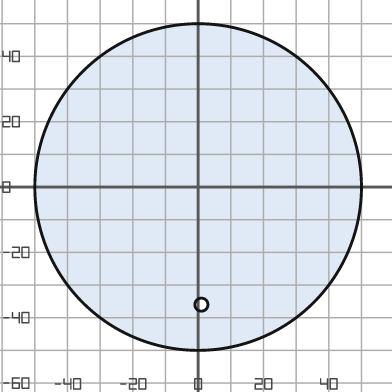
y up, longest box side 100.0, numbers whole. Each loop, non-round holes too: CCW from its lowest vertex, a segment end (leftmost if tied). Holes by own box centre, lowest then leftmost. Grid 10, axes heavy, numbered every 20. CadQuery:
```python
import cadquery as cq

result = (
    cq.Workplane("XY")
    .moveTo(0.0, 0.0)
    .circle(50.0)
    .moveTo(1.0, -36.0)
    .circle(2.0)
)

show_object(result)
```